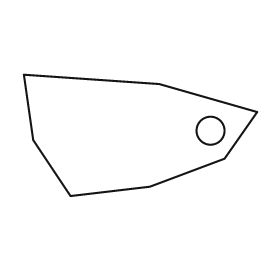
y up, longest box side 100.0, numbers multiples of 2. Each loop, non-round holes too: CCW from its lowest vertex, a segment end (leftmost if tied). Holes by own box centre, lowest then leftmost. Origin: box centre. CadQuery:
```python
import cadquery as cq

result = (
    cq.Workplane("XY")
    .moveTo(-30.0, -26.0)
    .lineTo(4.0, -22.0)
    .lineTo(36.0, -10.0)
    .lineTo(50.0, 10.0)
    .lineTo(8.0, 22.0)
    .lineTo(-50.0, 26.0)
    .lineTo(-46.0, -2.0)
    .close()
    .moveTo(30.0, 2.0)
    .circle(6.0)
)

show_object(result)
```